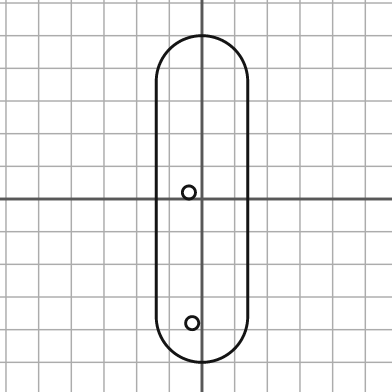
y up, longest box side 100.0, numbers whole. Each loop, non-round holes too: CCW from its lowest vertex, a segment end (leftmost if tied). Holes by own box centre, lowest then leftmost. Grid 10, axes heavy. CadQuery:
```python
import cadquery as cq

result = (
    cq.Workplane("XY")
    .moveTo(-14.0, -36.0)
    .threePointArc((0.0, -50.0), (14.0, -36.0))
    .lineTo(14.0, 36.0)
    .threePointArc((0.0, 50.0), (-14.0, 36.0))
    .close()
    .moveTo(-3.0, -38.0)
    .circle(2.0)
    .moveTo(-4.0, 2.0)
    .circle(2.0)
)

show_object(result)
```